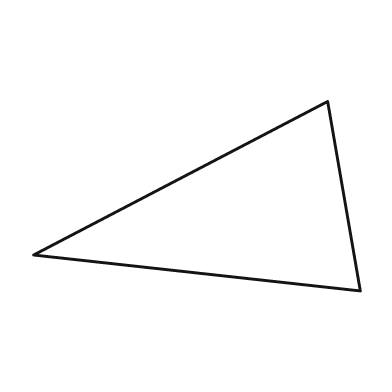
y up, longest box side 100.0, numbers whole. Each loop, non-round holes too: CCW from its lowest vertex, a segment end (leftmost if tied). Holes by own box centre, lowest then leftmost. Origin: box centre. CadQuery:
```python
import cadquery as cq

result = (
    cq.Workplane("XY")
    .moveTo(50.0, -29.0)
    .lineTo(40.0, 29.0)
    .lineTo(-50.0, -18.0)
    .close()
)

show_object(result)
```